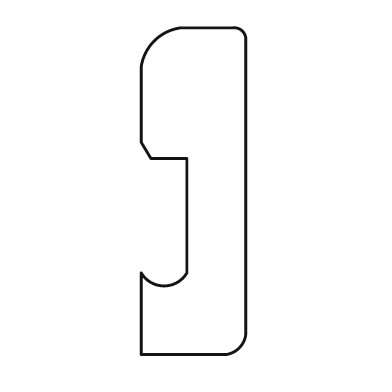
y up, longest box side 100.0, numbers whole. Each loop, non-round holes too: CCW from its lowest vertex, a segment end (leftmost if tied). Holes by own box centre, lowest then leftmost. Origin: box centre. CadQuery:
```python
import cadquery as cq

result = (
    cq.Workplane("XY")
    .moveTo(-16.0, -50.0)
    .lineTo(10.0, -50.0)
    .threePointArc((14.0, -48.0), (16.0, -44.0))
    .lineTo(16.0, 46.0)
    .threePointArc((15.0, 49.0), (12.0, 50.0))
    .lineTo(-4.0, 50.0)
    .threePointArc((-12.0, 46.0), (-16.0, 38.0))
    .lineTo(-16.0, 15.0)
    .lineTo(-13.0, 10.0)
    .lineTo(-2.0, 10.0)
    .lineTo(-2.0, -25.0)
    .threePointArc((-9.0, -29.0), (-16.0, -25.0))
    .close()
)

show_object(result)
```